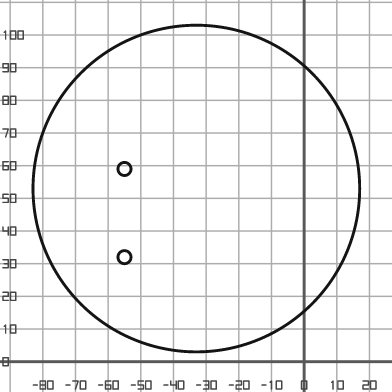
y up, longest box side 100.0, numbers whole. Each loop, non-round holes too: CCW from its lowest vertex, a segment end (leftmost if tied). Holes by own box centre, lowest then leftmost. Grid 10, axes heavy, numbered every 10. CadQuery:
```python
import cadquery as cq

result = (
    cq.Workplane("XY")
    .moveTo(-33.0, 53.0)
    .circle(50.0)
    .moveTo(-55.0, 32.0)
    .circle(2.0)
    .moveTo(-55.0, 59.0)
    .circle(2.0)
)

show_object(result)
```